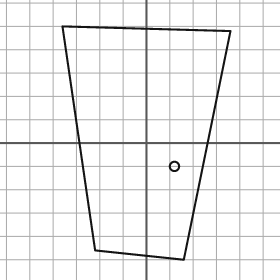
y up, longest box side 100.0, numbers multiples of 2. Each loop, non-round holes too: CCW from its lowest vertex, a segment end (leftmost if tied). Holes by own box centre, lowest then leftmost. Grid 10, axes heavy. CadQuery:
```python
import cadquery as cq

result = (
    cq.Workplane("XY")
    .moveTo(16.0, -50.0)
    .lineTo(36.0, 48.0)
    .lineTo(-36.0, 50.0)
    .lineTo(-22.0, -46.0)
    .close()
    .moveTo(12.0, -10.0)
    .circle(2.0)
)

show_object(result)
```